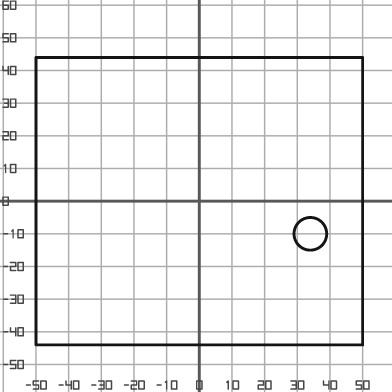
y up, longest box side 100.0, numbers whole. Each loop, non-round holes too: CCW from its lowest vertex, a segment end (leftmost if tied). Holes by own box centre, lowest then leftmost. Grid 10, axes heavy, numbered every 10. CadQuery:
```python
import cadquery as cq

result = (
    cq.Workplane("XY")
    .moveTo(-50.0, -44.0)
    .lineTo(50.0, -44.0)
    .lineTo(50.0, 44.0)
    .lineTo(-50.0, 44.0)
    .close()
    .moveTo(34.0, -10.0)
    .circle(5.0)
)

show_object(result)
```